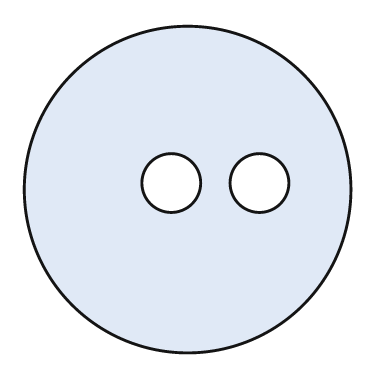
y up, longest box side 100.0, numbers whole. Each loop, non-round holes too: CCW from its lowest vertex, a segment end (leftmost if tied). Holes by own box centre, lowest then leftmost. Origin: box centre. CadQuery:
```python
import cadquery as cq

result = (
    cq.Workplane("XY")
    .moveTo(0.0, 0.0)
    .circle(50.0)
    .moveTo(-5.0, 2.0)
    .circle(9.0)
    .moveTo(22.0, 2.0)
    .circle(9.0)
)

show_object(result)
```